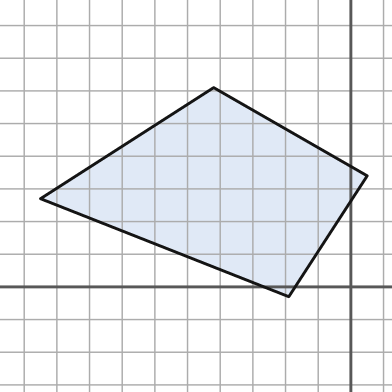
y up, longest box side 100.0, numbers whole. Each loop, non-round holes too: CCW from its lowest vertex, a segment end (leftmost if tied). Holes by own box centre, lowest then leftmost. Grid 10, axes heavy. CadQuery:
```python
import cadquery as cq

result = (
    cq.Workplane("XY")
    .moveTo(-19.0, -3.0)
    .lineTo(5.0, 34.0)
    .lineTo(-42.0, 61.0)
    .lineTo(-95.0, 27.0)
    .close()
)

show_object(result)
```